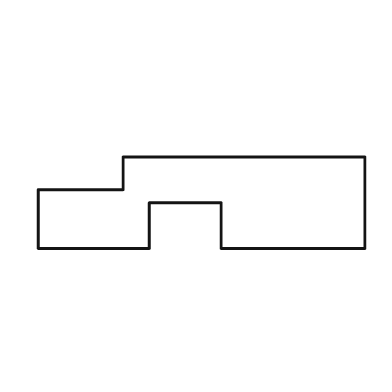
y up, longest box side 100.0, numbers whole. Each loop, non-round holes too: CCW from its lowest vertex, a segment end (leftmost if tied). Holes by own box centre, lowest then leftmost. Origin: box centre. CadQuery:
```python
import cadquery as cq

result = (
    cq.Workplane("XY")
    .moveTo(-50.0, -14.0)
    .lineTo(-16.0, -14.0)
    .lineTo(-16.0, 0.0)
    .lineTo(6.0, 0.0)
    .lineTo(6.0, -14.0)
    .lineTo(50.0, -14.0)
    .lineTo(50.0, 14.0)
    .lineTo(-24.0, 14.0)
    .lineTo(-24.0, 4.0)
    .lineTo(-50.0, 4.0)
    .close()
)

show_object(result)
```